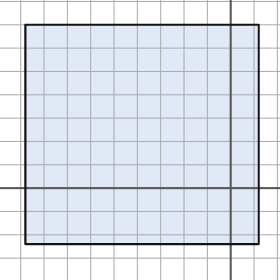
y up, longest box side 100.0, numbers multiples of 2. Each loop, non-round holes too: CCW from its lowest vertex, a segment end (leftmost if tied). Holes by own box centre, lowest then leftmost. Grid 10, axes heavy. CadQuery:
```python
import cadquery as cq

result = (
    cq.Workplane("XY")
    .moveTo(-88.0, -24.0)
    .lineTo(12.0, -24.0)
    .lineTo(12.0, 70.0)
    .lineTo(-88.0, 70.0)
    .close()
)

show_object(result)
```